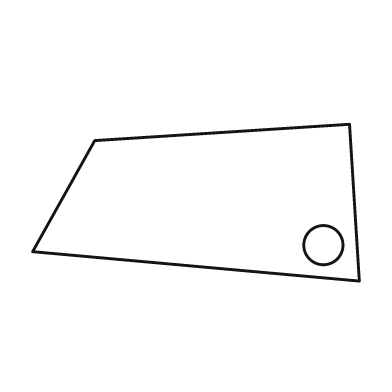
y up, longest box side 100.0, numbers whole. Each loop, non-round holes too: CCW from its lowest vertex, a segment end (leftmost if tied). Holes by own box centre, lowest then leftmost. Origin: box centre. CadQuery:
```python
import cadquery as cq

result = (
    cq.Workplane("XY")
    .moveTo(50.0, -24.0)
    .lineTo(47.0, 24.0)
    .lineTo(-31.0, 19.0)
    .lineTo(-50.0, -15.0)
    .close()
    .moveTo(39.0, -13.0)
    .circle(6.0)
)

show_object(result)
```